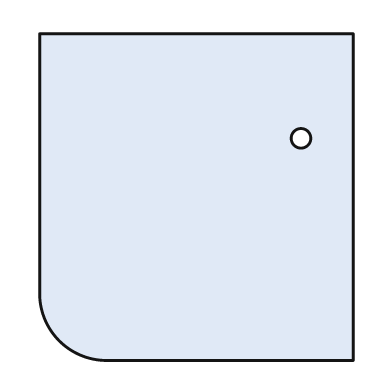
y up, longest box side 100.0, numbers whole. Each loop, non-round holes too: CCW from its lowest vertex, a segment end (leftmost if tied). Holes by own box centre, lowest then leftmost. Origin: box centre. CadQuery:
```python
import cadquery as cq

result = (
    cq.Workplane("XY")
    .moveTo(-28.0, -50.0)
    .lineTo(48.0, -50.0)
    .lineTo(48.0, 50.0)
    .lineTo(-48.0, 50.0)
    .lineTo(-48.0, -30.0)
    .threePointArc((-42.0, -44.0), (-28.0, -50.0))
    .close()
    .moveTo(32.0, 18.0)
    .circle(3.0)
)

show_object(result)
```